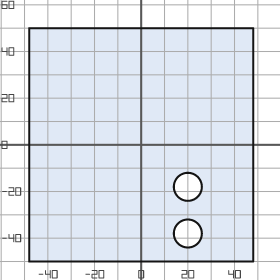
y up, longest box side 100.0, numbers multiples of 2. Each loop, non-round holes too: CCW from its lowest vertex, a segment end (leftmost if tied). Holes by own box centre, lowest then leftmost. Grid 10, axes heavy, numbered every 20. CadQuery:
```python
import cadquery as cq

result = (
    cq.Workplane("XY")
    .moveTo(-48.0, -50.0)
    .lineTo(48.0, -50.0)
    .lineTo(48.0, 50.0)
    .lineTo(-48.0, 50.0)
    .close()
    .moveTo(20.0, -38.0)
    .circle(6.0)
    .moveTo(20.0, -18.0)
    .circle(6.0)
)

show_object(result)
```